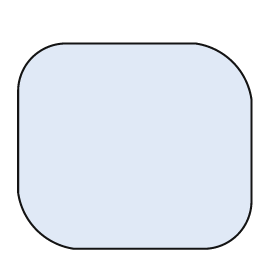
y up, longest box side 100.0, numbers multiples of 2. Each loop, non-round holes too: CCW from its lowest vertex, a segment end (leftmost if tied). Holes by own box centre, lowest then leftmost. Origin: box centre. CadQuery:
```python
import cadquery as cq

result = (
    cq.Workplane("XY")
    .moveTo(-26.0, -44.0)
    .lineTo(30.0, -44.0)
    .threePointArc((44.0, -38.0), (50.0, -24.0))
    .lineTo(50.0, 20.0)
    .threePointArc((42.0, 36.0), (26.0, 44.0))
    .lineTo(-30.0, 44.0)
    .threePointArc((-44.0, 38.0), (-50.0, 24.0))
    .lineTo(-50.0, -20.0)
    .threePointArc((-42.0, -36.0), (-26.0, -44.0))
    .close()
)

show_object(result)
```